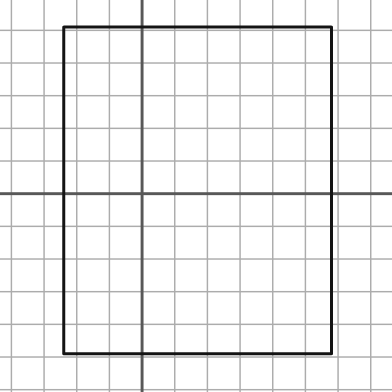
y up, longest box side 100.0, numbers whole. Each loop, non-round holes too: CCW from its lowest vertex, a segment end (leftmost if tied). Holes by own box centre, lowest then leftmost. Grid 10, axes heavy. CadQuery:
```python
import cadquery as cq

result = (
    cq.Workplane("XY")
    .moveTo(-24.0, -49.0)
    .lineTo(58.0, -49.0)
    .lineTo(58.0, 51.0)
    .lineTo(-24.0, 51.0)
    .close()
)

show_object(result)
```